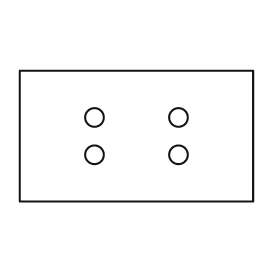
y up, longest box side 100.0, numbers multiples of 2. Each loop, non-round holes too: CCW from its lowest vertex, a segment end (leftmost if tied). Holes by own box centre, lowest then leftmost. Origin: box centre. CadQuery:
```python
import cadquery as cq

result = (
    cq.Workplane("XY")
    .moveTo(-50.0, -28.0)
    .lineTo(50.0, -28.0)
    .lineTo(50.0, 28.0)
    .lineTo(-50.0, 28.0)
    .close()
    .moveTo(-18.0, -8.0)
    .circle(4.0)
    .moveTo(18.0, -8.0)
    .circle(4.0)
    .moveTo(-18.0, 8.0)
    .circle(4.0)
    .moveTo(18.0, 8.0)
    .circle(4.0)
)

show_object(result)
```